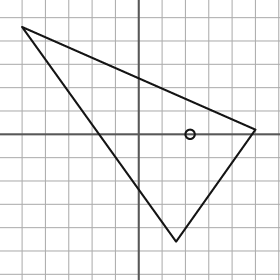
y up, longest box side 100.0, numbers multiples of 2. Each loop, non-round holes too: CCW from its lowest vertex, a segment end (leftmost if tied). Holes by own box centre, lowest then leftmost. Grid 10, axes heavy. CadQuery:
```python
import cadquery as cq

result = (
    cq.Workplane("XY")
    .moveTo(16.0, -46.0)
    .lineTo(50.0, 2.0)
    .lineTo(-50.0, 46.0)
    .close()
    .moveTo(22.0, 0.0)
    .circle(2.0)
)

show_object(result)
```